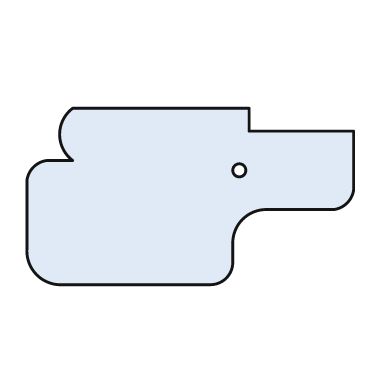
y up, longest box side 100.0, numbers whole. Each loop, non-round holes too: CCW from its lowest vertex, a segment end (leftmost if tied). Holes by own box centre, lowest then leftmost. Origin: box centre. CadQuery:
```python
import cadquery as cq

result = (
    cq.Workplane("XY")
    .moveTo(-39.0, -27.0)
    .lineTo(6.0, -27.0)
    .threePointArc((11.0, -25.0), (13.0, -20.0))
    .lineTo(13.0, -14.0)
    .threePointArc((16.0, -7.0), (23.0, -4.0))
    .lineTo(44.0, -4.0)
    .threePointArc((48.0, -2.0), (50.0, 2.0))
    .lineTo(50.0, 20.0)
    .lineTo(18.0, 20.0)
    .lineTo(18.0, 27.0)
    .lineTo(-36.0, 27.0)
    .threePointArc((-40.0, 19.0), (-36.0, 11.0))
    .lineTo(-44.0, 11.0)
    .threePointArc((-48.0, 9.0), (-50.0, 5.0))
    .lineTo(-50.0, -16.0)
    .threePointArc((-47.0, -24.0), (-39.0, -27.0))
    .close()
    .moveTo(15.0, 8.0)
    .circle(2.0)
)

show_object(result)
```